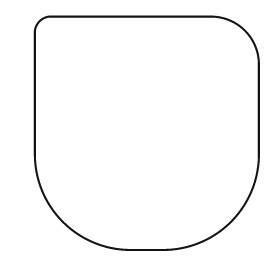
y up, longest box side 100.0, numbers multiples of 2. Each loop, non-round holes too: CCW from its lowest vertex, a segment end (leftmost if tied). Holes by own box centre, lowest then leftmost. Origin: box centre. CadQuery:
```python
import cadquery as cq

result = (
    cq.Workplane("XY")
    .moveTo(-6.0, -50.0)
    .lineTo(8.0, -50.0)
    .threePointArc((36.0, -38.0), (48.0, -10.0))
    .lineTo(48.0, 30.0)
    .threePointArc((42.0, 44.0), (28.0, 50.0))
    .lineTo(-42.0, 50.0)
    .threePointArc((-46.0, 48.0), (-48.0, 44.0))
    .lineTo(-48.0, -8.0)
    .threePointArc((-36.0, -38.0), (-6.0, -50.0))
    .close()
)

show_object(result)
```